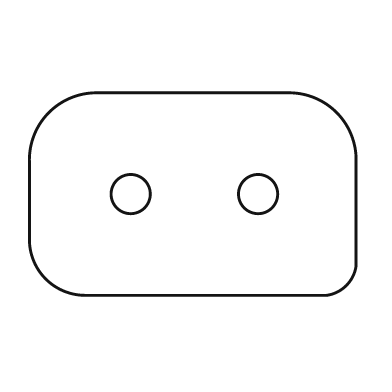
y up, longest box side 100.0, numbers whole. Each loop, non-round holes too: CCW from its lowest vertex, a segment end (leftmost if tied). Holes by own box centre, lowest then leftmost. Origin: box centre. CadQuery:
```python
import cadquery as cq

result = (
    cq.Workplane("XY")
    .moveTo(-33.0, -31.0)
    .lineTo(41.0, -31.0)
    .threePointArc((47.0, -28.0), (50.0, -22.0))
    .lineTo(50.0, 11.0)
    .threePointArc((44.0, 25.0), (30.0, 31.0))
    .lineTo(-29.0, 31.0)
    .threePointArc((-44.0, 25.0), (-50.0, 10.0))
    .lineTo(-50.0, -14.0)
    .threePointArc((-45.0, -26.0), (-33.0, -31.0))
    .close()
    .moveTo(-19.0, 0.0)
    .circle(6.0)
    .moveTo(20.0, 0.0)
    .circle(6.0)
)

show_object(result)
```